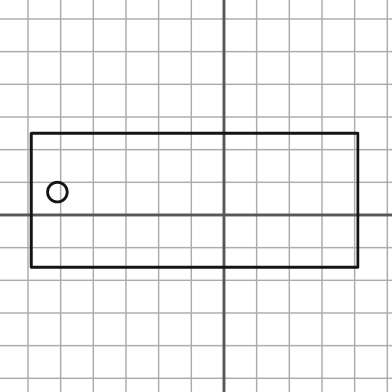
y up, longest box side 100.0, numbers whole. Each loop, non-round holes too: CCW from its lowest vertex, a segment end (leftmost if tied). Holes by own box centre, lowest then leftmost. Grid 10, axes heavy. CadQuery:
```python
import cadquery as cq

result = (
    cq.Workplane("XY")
    .moveTo(-59.0, -16.0)
    .lineTo(41.0, -16.0)
    .lineTo(41.0, 25.0)
    .lineTo(-59.0, 25.0)
    .close()
    .moveTo(-51.0, 7.0)
    .circle(3.0)
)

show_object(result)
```